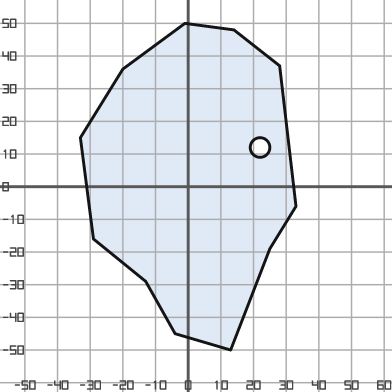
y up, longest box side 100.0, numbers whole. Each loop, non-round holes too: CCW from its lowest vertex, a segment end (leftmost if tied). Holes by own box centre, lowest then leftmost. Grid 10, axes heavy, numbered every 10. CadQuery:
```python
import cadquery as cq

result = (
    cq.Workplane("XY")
    .moveTo(13.0, -50.0)
    .lineTo(25.0, -19.0)
    .lineTo(33.0, -6.0)
    .lineTo(28.0, 37.0)
    .lineTo(14.0, 48.0)
    .lineTo(-1.0, 50.0)
    .lineTo(-20.0, 36.0)
    .lineTo(-33.0, 15.0)
    .lineTo(-29.0, -16.0)
    .lineTo(-13.0, -29.0)
    .lineTo(-4.0, -45.0)
    .close()
    .moveTo(22.0, 12.0)
    .circle(3.0)
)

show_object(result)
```